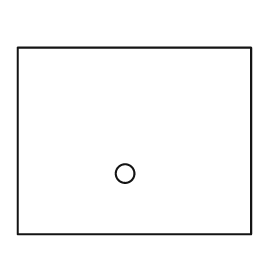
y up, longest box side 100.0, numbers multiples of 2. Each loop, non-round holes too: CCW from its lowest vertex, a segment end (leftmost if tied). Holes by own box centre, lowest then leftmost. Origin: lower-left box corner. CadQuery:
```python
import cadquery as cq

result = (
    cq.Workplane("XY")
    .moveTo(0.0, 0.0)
    .lineTo(100.0, 0.0)
    .lineTo(100.0, 80.0)
    .lineTo(0.0, 80.0)
    .close()
    .moveTo(46.0, 26.0)
    .circle(4.0)
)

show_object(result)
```